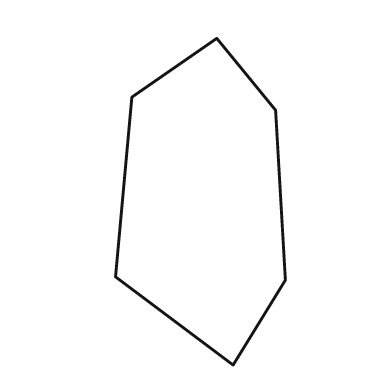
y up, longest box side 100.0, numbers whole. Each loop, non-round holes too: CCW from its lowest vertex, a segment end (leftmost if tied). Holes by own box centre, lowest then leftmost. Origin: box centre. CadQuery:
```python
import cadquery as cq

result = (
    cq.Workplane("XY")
    .moveTo(10.0, -50.0)
    .lineTo(26.0, -24.0)
    .lineTo(23.0, 28.0)
    .lineTo(5.0, 50.0)
    .lineTo(-21.0, 32.0)
    .lineTo(-26.0, -23.0)
    .close()
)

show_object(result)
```